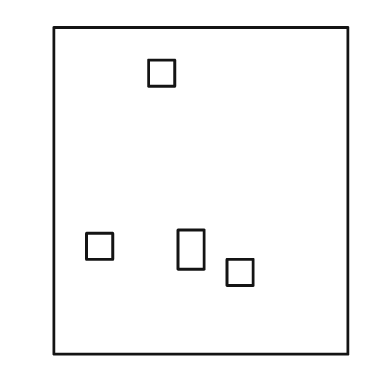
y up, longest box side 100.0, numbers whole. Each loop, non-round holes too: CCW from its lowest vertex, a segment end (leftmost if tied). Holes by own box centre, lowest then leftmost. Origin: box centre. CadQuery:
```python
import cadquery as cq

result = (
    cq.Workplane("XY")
    .moveTo(-45.0, -50.0)
    .lineTo(45.0, -50.0)
    .lineTo(45.0, 50.0)
    .lineTo(-45.0, 50.0)
    .close()
    .moveTo(8.0, -29.0)
    .lineTo(16.0, -29.0)
    .lineTo(16.0, -21.0)
    .lineTo(8.0, -21.0)
    .close()
    .moveTo(-7.0, -24.0)
    .lineTo(1.0, -24.0)
    .lineTo(1.0, -12.0)
    .lineTo(-7.0, -12.0)
    .close()
    .moveTo(-35.0, -21.0)
    .lineTo(-27.0, -21.0)
    .lineTo(-27.0, -13.0)
    .lineTo(-35.0, -13.0)
    .close()
    .moveTo(-16.0, 32.0)
    .lineTo(-8.0, 32.0)
    .lineTo(-8.0, 40.0)
    .lineTo(-16.0, 40.0)
    .close()
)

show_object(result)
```